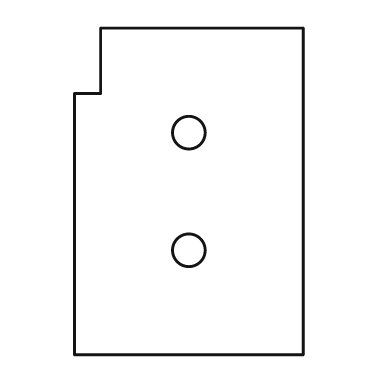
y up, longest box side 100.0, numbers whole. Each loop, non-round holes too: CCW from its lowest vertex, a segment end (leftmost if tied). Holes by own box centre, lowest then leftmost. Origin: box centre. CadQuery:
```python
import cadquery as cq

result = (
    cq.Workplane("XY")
    .moveTo(-35.0, -50.0)
    .lineTo(35.0, -50.0)
    .lineTo(35.0, 50.0)
    .lineTo(-27.0, 50.0)
    .lineTo(-27.0, 30.0)
    .lineTo(-35.0, 30.0)
    .close()
    .moveTo(0.0, -18.0)
    .circle(5.0)
    .moveTo(0.0, 18.0)
    .circle(5.0)
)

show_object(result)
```